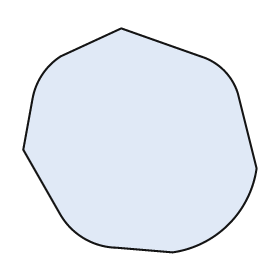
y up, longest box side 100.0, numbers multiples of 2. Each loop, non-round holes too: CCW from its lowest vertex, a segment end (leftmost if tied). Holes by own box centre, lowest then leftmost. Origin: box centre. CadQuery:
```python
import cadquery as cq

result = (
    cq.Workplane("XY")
    .moveTo(14.0, -48.0)
    .threePointArc((38.0, -36.0), (50.0, -12.0))
    .lineTo(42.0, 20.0)
    .threePointArc((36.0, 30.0), (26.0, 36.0))
    .lineTo(-8.0, 48.0)
    .lineTo(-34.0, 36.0)
    .threePointArc((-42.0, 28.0), (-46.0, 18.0))
    .lineTo(-50.0, -4.0)
    .lineTo(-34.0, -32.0)
    .threePointArc((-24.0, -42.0), (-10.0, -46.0))
    .close()
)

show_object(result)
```